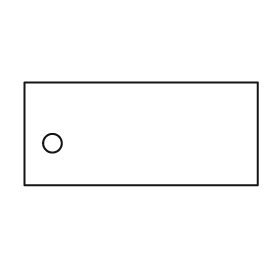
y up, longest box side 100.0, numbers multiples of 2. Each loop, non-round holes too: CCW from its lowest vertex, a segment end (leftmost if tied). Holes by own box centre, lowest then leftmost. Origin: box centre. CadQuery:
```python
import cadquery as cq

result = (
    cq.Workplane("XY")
    .moveTo(-50.0, -22.0)
    .lineTo(50.0, -22.0)
    .lineTo(50.0, 22.0)
    .lineTo(-50.0, 22.0)
    .close()
    .moveTo(-38.0, -4.0)
    .circle(4.0)
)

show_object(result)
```